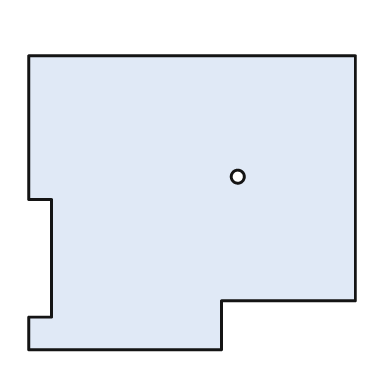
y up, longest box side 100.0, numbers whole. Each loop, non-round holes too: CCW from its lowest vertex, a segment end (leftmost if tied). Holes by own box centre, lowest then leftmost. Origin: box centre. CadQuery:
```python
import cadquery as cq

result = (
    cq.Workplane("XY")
    .moveTo(-50.0, -45.0)
    .lineTo(9.0, -45.0)
    .lineTo(9.0, -30.0)
    .lineTo(50.0, -30.0)
    .lineTo(50.0, 45.0)
    .lineTo(-50.0, 45.0)
    .lineTo(-50.0, 1.0)
    .lineTo(-43.0, 1.0)
    .lineTo(-43.0, -35.0)
    .lineTo(-50.0, -35.0)
    .close()
    .moveTo(14.0, 8.0)
    .circle(2.0)
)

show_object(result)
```